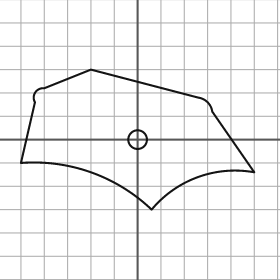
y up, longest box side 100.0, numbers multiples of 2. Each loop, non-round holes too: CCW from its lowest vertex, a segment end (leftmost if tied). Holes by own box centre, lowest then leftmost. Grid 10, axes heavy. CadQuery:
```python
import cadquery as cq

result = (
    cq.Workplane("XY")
    .moveTo(6.0, -30.0)
    .threePointArc((26.0, -16.0), (50.0, -14.0))
    .lineTo(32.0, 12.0)
    .threePointArc((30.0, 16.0), (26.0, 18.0))
    .lineTo(-20.0, 30.0)
    .lineTo(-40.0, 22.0)
    .threePointArc((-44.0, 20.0), (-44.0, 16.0))
    .lineTo(-50.0, -10.0)
    .threePointArc((-20.0, -14.0), (6.0, -30.0))
    .close()
    .moveTo(0.0, 0.0)
    .circle(4.0)
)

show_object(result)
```